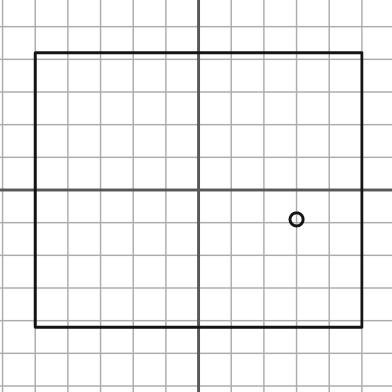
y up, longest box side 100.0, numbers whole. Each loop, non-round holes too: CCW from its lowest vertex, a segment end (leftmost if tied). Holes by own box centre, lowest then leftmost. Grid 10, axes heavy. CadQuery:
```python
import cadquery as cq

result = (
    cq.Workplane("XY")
    .moveTo(-50.0, -42.0)
    .lineTo(50.0, -42.0)
    .lineTo(50.0, 42.0)
    .lineTo(-50.0, 42.0)
    .close()
    .moveTo(30.0, -9.0)
    .circle(2.0)
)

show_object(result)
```